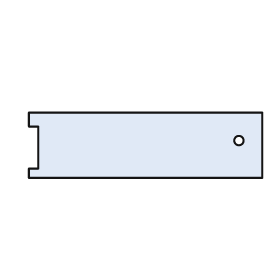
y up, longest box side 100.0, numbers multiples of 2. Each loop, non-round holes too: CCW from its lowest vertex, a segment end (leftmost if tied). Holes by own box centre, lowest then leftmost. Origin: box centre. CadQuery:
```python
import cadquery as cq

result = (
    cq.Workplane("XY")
    .moveTo(-50.0, -14.0)
    .lineTo(50.0, -14.0)
    .lineTo(50.0, 14.0)
    .lineTo(-50.0, 14.0)
    .lineTo(-50.0, 8.0)
    .lineTo(-46.0, 8.0)
    .lineTo(-46.0, -10.0)
    .lineTo(-50.0, -10.0)
    .close()
    .moveTo(40.0, 2.0)
    .circle(2.0)
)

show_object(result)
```